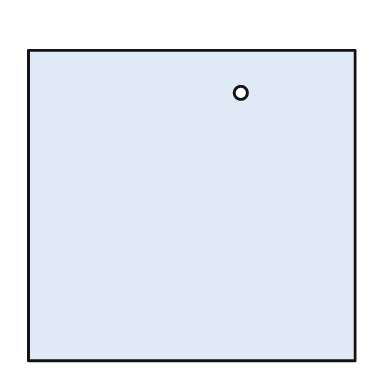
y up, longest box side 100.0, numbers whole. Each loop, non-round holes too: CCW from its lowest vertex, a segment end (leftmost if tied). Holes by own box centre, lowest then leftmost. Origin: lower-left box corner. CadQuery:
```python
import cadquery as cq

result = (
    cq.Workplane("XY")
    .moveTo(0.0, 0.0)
    .lineTo(100.0, 0.0)
    .lineTo(100.0, 95.0)
    .lineTo(0.0, 95.0)
    .close()
    .moveTo(65.0, 82.0)
    .circle(2.0)
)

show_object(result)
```